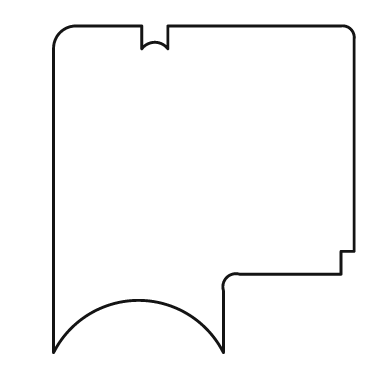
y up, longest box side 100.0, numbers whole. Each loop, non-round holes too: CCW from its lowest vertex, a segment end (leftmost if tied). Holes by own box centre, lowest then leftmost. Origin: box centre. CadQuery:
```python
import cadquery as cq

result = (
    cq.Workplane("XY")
    .moveTo(-46.0, -50.0)
    .threePointArc((-20.0, -34.0), (6.0, -50.0))
    .lineTo(6.0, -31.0)
    .threePointArc((7.0, -27.0), (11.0, -26.0))
    .lineTo(42.0, -26.0)
    .lineTo(42.0, -19.0)
    .lineTo(46.0, -19.0)
    .lineTo(46.0, 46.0)
    .threePointArc((45.0, 49.0), (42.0, 50.0))
    .lineTo(-11.0, 50.0)
    .lineTo(-11.0, 43.0)
    .threePointArc((-15.0, 45.0), (-19.0, 43.0))
    .lineTo(-19.0, 50.0)
    .lineTo(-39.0, 50.0)
    .threePointArc((-44.0, 48.0), (-46.0, 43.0))
    .close()
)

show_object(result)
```